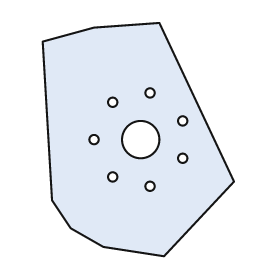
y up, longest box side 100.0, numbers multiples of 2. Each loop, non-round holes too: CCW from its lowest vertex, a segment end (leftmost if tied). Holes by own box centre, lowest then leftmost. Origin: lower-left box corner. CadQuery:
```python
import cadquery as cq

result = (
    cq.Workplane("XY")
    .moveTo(52.0, 0.0)
    .lineTo(82.0, 32.0)
    .lineTo(50.0, 100.0)
    .lineTo(22.0, 98.0)
    .lineTo(0.0, 92.0)
    .lineTo(4.0, 24.0)
    .lineTo(12.0, 12.0)
    .lineTo(26.0, 4.0)
    .close()
    .moveTo(46.0, 30.0)
    .circle(2.0)
    .moveTo(30.0, 34.0)
    .circle(2.0)
    .moveTo(60.0, 42.0)
    .circle(2.0)
    .moveTo(22.0, 50.0)
    .circle(2.0)
    .moveTo(42.0, 50.0)
    .circle(8.0)
    .moveTo(60.0, 58.0)
    .circle(2.0)
    .moveTo(30.0, 66.0)
    .circle(2.0)
    .moveTo(46.0, 70.0)
    .circle(2.0)
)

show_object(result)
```